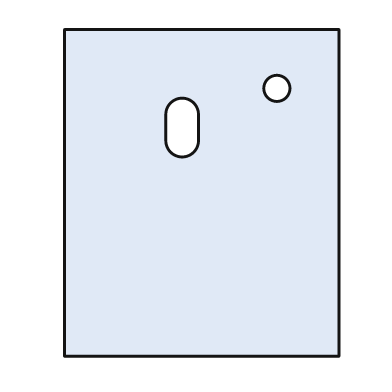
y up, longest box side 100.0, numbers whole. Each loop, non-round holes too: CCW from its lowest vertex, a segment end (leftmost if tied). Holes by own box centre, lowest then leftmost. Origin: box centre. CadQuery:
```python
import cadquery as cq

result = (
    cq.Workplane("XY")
    .moveTo(-42.0, -50.0)
    .lineTo(42.0, -50.0)
    .lineTo(42.0, 50.0)
    .lineTo(-42.0, 50.0)
    .close()
    .moveTo(-11.0, 16.0)
    .threePointArc((-6.0, 11.0), (-1.0, 16.0))
    .lineTo(-1.0, 24.0)
    .threePointArc((-6.0, 29.0), (-11.0, 24.0))
    .close()
    .moveTo(23.0, 32.0)
    .circle(4.0)
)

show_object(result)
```